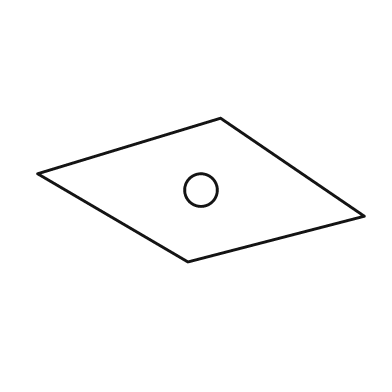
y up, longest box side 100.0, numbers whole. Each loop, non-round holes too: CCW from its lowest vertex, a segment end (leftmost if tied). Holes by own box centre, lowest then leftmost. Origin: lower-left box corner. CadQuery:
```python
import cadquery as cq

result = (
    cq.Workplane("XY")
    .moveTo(46.0, 0.0)
    .lineTo(100.0, 14.0)
    .lineTo(56.0, 44.0)
    .lineTo(0.0, 27.0)
    .close()
    .moveTo(50.0, 22.0)
    .circle(5.0)
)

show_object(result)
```